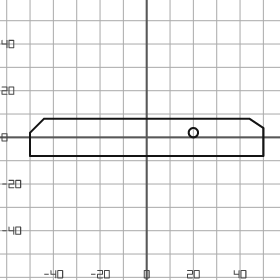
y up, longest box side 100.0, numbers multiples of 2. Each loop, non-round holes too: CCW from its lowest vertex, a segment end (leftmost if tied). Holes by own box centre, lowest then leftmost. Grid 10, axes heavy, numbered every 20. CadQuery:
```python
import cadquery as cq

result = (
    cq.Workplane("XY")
    .moveTo(-50.0, -8.0)
    .lineTo(50.0, -8.0)
    .lineTo(50.0, 4.0)
    .lineTo(44.0, 8.0)
    .lineTo(-44.0, 8.0)
    .lineTo(-50.0, 2.0)
    .close()
    .moveTo(20.0, 2.0)
    .circle(2.0)
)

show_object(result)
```